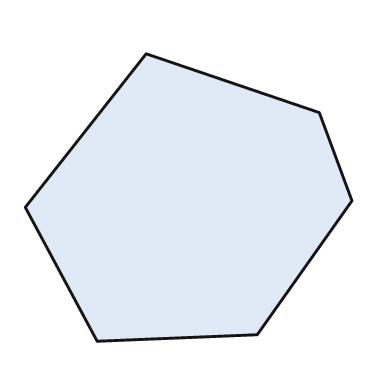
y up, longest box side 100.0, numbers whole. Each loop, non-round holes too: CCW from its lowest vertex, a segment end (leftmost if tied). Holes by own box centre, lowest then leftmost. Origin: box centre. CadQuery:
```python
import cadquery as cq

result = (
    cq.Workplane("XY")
    .moveTo(-28.0, -44.0)
    .lineTo(21.0, -42.0)
    .lineTo(50.0, -1.0)
    .lineTo(40.0, 26.0)
    .lineTo(-13.0, 44.0)
    .lineTo(-50.0, -3.0)
    .close()
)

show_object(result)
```